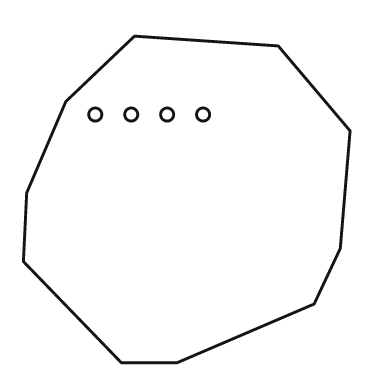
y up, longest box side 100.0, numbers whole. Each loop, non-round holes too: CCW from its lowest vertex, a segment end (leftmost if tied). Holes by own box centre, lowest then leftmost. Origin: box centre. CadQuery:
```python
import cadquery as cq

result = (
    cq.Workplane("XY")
    .moveTo(-20.0, -50.0)
    .lineTo(-3.0, -50.0)
    .lineTo(39.0, -32.0)
    .lineTo(47.0, -15.0)
    .lineTo(50.0, 21.0)
    .lineTo(28.0, 47.0)
    .lineTo(-16.0, 50.0)
    .lineTo(-37.0, 30.0)
    .lineTo(-49.0, 2.0)
    .lineTo(-50.0, -19.0)
    .close()
    .moveTo(-28.0, 26.0)
    .circle(2.0)
    .moveTo(-17.0, 26.0)
    .circle(2.0)
    .moveTo(-6.0, 26.0)
    .circle(2.0)
    .moveTo(5.0, 26.0)
    .circle(2.0)
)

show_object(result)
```